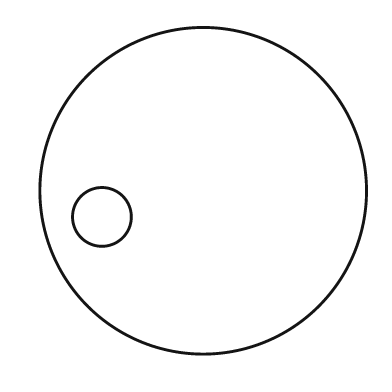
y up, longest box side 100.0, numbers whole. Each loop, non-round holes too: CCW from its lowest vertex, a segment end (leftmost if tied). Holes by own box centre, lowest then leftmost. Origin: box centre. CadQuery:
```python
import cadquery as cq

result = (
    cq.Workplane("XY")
    .moveTo(0.0, 0.0)
    .circle(50.0)
    .moveTo(-31.0, -8.0)
    .circle(9.0)
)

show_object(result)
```